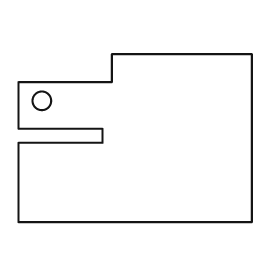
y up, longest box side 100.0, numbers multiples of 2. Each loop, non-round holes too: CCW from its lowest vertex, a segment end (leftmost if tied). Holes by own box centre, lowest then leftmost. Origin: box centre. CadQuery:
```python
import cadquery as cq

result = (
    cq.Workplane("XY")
    .moveTo(-50.0, -36.0)
    .lineTo(50.0, -36.0)
    .lineTo(50.0, 36.0)
    .lineTo(-10.0, 36.0)
    .lineTo(-10.0, 24.0)
    .lineTo(-50.0, 24.0)
    .lineTo(-50.0, 4.0)
    .lineTo(-14.0, 4.0)
    .lineTo(-14.0, -2.0)
    .lineTo(-50.0, -2.0)
    .close()
    .moveTo(-40.0, 16.0)
    .circle(4.0)
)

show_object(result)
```